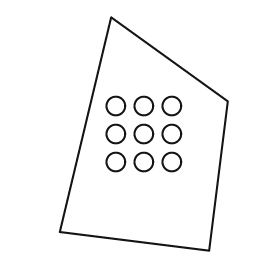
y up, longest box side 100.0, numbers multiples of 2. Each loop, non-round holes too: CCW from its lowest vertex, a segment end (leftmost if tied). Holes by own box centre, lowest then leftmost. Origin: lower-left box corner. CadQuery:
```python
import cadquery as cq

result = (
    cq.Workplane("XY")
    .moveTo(64.0, 0.0)
    .lineTo(72.0, 64.0)
    .lineTo(22.0, 100.0)
    .lineTo(0.0, 8.0)
    .close()
    .moveTo(24.0, 38.0)
    .circle(4.0)
    .moveTo(36.0, 38.0)
    .circle(4.0)
    .moveTo(48.0, 38.0)
    .circle(4.0)
    .moveTo(24.0, 50.0)
    .circle(4.0)
    .moveTo(36.0, 50.0)
    .circle(4.0)
    .moveTo(48.0, 50.0)
    .circle(4.0)
    .moveTo(24.0, 62.0)
    .circle(4.0)
    .moveTo(36.0, 62.0)
    .circle(4.0)
    .moveTo(48.0, 62.0)
    .circle(4.0)
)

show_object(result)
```